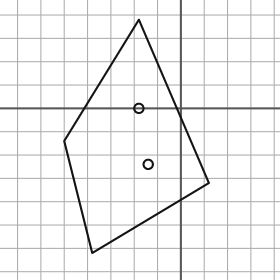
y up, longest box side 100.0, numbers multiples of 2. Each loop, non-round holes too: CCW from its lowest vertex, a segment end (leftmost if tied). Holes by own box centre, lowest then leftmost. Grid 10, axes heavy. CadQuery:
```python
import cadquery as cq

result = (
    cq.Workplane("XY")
    .moveTo(-38.0, -62.0)
    .lineTo(12.0, -32.0)
    .lineTo(-18.0, 38.0)
    .lineTo(-50.0, -14.0)
    .close()
    .moveTo(-14.0, -24.0)
    .circle(2.0)
    .moveTo(-18.0, 0.0)
    .circle(2.0)
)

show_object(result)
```